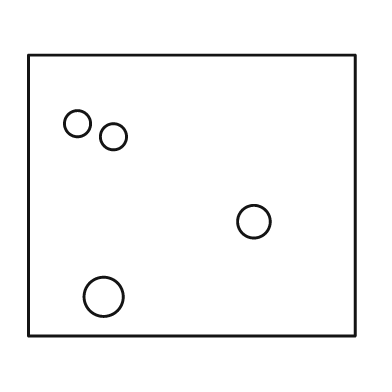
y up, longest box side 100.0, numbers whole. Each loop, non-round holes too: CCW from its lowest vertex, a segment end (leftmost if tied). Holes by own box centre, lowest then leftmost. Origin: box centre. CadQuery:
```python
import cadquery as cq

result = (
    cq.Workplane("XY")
    .moveTo(-50.0, -43.0)
    .lineTo(50.0, -43.0)
    .lineTo(50.0, 43.0)
    .lineTo(-50.0, 43.0)
    .close()
    .moveTo(-27.0, -31.0)
    .circle(6.0)
    .moveTo(19.0, -8.0)
    .circle(5.0)
    .moveTo(-24.0, 18.0)
    .circle(4.0)
    .moveTo(-35.0, 22.0)
    .circle(4.0)
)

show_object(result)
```